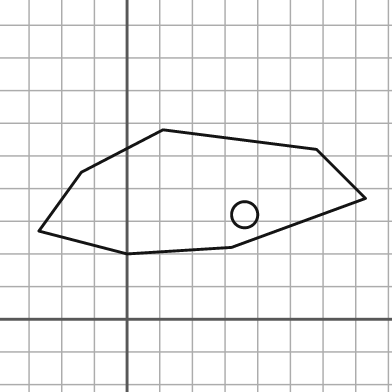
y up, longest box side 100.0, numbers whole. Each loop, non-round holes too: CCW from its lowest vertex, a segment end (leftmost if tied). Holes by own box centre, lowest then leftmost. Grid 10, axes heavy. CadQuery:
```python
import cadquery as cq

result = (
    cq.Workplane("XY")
    .moveTo(0.0, 20.0)
    .lineTo(32.0, 22.0)
    .lineTo(73.0, 37.0)
    .lineTo(58.0, 52.0)
    .lineTo(11.0, 58.0)
    .lineTo(-14.0, 45.0)
    .lineTo(-27.0, 27.0)
    .close()
    .moveTo(36.0, 32.0)
    .circle(4.0)
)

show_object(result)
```